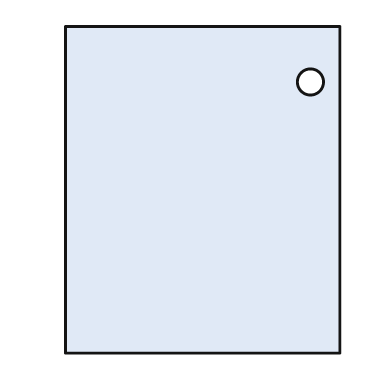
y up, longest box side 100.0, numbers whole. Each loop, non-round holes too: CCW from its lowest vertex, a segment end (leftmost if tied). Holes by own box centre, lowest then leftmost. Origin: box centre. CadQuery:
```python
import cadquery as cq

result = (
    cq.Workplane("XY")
    .moveTo(-42.0, -50.0)
    .lineTo(42.0, -50.0)
    .lineTo(42.0, 50.0)
    .lineTo(-42.0, 50.0)
    .close()
    .moveTo(33.0, 33.0)
    .circle(4.0)
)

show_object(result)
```